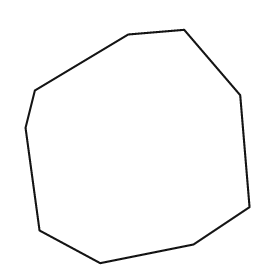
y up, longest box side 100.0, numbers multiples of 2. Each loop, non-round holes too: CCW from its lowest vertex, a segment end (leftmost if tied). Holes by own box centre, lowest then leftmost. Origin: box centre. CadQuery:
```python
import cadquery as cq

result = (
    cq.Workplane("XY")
    .moveTo(-16.0, -50.0)
    .lineTo(24.0, -42.0)
    .lineTo(48.0, -26.0)
    .lineTo(44.0, 22.0)
    .lineTo(20.0, 50.0)
    .lineTo(-4.0, 48.0)
    .lineTo(-44.0, 24.0)
    .lineTo(-48.0, 8.0)
    .lineTo(-42.0, -36.0)
    .close()
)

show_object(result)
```